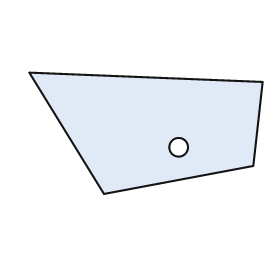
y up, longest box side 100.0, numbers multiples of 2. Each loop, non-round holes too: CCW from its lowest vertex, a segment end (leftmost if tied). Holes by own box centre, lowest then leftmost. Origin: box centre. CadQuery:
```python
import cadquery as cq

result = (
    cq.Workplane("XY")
    .moveTo(-18.0, -26.0)
    .lineTo(46.0, -14.0)
    .lineTo(50.0, 22.0)
    .lineTo(-50.0, 26.0)
    .close()
    .moveTo(14.0, -6.0)
    .circle(4.0)
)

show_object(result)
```